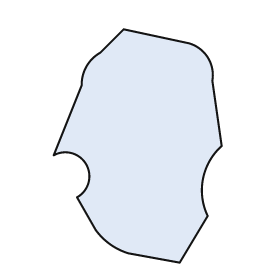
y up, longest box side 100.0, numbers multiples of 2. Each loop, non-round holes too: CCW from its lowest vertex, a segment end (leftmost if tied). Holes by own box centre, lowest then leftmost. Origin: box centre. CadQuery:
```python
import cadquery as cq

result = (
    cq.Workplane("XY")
    .moveTo(18.0, -50.0)
    .lineTo(30.0, -30.0)
    .threePointArc((28.0, -14.0), (36.0, 0.0))
    .lineTo(32.0, 28.0)
    .threePointArc((30.0, 38.0), (22.0, 44.0))
    .lineTo(-6.0, 50.0)
    .lineTo(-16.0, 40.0)
    .threePointArc((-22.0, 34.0), (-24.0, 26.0))
    .lineTo(-36.0, -4.0)
    .threePointArc((-22.0, -8.0), (-26.0, -22.0))
    .lineTo(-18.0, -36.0)
    .threePointArc((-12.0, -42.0), (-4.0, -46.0))
    .close()
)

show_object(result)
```